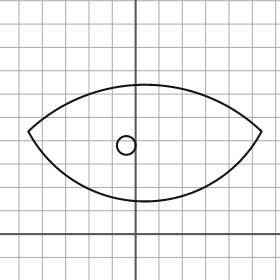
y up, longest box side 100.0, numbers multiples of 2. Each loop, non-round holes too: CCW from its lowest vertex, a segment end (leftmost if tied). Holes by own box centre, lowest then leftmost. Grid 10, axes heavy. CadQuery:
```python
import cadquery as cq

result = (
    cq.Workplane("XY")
    .moveTo(-46.0, 44.0)
    .threePointArc((4.0, 14.0), (54.0, 44.0))
    .threePointArc((4.0, 64.0), (-46.0, 44.0))
    .close()
    .moveTo(-4.0, 38.0)
    .circle(4.0)
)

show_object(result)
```